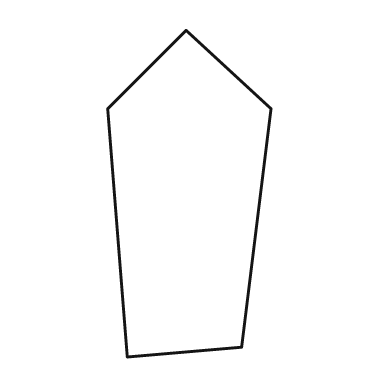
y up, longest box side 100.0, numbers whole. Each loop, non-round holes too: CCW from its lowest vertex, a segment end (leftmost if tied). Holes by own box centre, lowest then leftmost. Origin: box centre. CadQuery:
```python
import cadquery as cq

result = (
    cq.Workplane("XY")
    .moveTo(-19.0, -50.0)
    .lineTo(16.0, -47.0)
    .lineTo(25.0, 26.0)
    .lineTo(-1.0, 50.0)
    .lineTo(-25.0, 26.0)
    .close()
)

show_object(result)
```